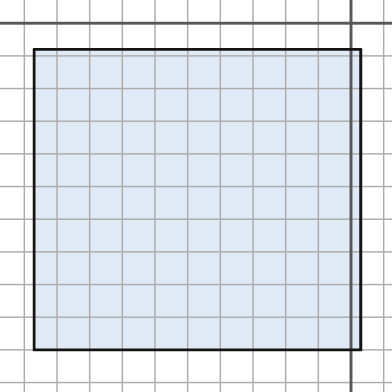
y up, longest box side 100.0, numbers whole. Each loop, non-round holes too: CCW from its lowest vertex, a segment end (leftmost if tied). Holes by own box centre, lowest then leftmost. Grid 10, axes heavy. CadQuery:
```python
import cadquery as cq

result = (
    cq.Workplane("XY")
    .moveTo(-97.0, -100.0)
    .lineTo(3.0, -100.0)
    .lineTo(3.0, -8.0)
    .lineTo(-97.0, -8.0)
    .close()
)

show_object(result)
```